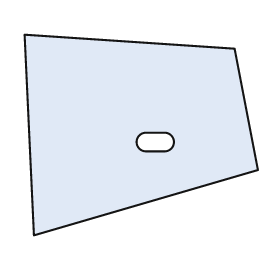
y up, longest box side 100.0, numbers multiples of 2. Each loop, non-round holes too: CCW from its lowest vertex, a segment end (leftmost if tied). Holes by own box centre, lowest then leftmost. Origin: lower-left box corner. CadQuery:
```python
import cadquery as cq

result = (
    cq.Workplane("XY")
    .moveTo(4.0, 0.0)
    .lineTo(100.0, 28.0)
    .lineTo(90.0, 80.0)
    .lineTo(0.0, 86.0)
    .close()
    .moveTo(52.0, 36.0)
    .lineTo(60.0, 36.0)
    .threePointArc((64.0, 40.0), (60.0, 44.0))
    .lineTo(52.0, 44.0)
    .threePointArc((48.0, 40.0), (52.0, 36.0))
    .close()
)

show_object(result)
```